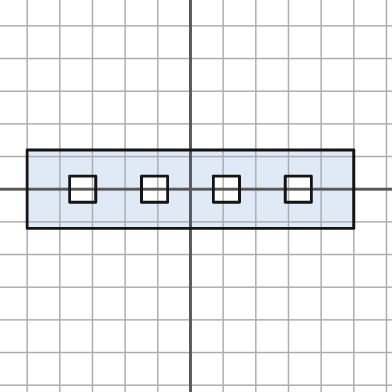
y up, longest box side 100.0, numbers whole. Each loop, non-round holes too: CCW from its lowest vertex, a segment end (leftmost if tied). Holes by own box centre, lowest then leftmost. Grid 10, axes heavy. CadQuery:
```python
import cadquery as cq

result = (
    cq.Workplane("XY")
    .moveTo(-50.0, -12.0)
    .lineTo(50.0, -12.0)
    .lineTo(50.0, 12.0)
    .lineTo(-50.0, 12.0)
    .close()
    .moveTo(-37.0, -4.0)
    .lineTo(-29.0, -4.0)
    .lineTo(-29.0, 4.0)
    .lineTo(-37.0, 4.0)
    .close()
    .moveTo(-15.0, -4.0)
    .lineTo(-7.0, -4.0)
    .lineTo(-7.0, 4.0)
    .lineTo(-15.0, 4.0)
    .close()
    .moveTo(7.0, -4.0)
    .lineTo(15.0, -4.0)
    .lineTo(15.0, 4.0)
    .lineTo(7.0, 4.0)
    .close()
    .moveTo(29.0, -4.0)
    .lineTo(37.0, -4.0)
    .lineTo(37.0, 4.0)
    .lineTo(29.0, 4.0)
    .close()
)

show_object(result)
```